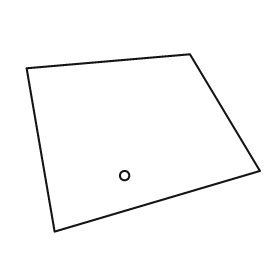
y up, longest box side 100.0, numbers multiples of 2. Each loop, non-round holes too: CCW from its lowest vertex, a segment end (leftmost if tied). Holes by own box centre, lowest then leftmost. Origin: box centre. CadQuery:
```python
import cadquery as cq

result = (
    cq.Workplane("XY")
    .moveTo(-38.0, -38.0)
    .lineTo(50.0, -12.0)
    .lineTo(20.0, 38.0)
    .lineTo(-50.0, 32.0)
    .close()
    .moveTo(-8.0, -14.0)
    .circle(2.0)
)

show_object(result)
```